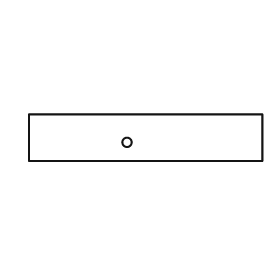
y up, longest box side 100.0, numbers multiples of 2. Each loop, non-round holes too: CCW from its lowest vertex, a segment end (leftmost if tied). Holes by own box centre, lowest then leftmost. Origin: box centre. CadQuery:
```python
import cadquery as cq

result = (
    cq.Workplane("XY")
    .moveTo(-50.0, -10.0)
    .lineTo(50.0, -10.0)
    .lineTo(50.0, 10.0)
    .lineTo(-50.0, 10.0)
    .close()
    .moveTo(-8.0, -2.0)
    .circle(2.0)
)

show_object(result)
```